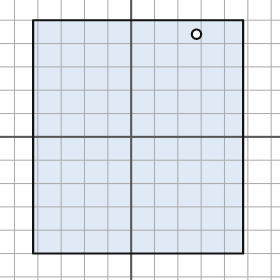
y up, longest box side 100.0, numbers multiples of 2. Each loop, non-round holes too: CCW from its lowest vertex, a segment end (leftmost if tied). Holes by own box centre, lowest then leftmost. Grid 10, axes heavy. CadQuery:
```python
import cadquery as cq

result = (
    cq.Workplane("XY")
    .moveTo(-42.0, -50.0)
    .lineTo(48.0, -50.0)
    .lineTo(48.0, 50.0)
    .lineTo(-42.0, 50.0)
    .close()
    .moveTo(28.0, 44.0)
    .circle(2.0)
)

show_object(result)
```